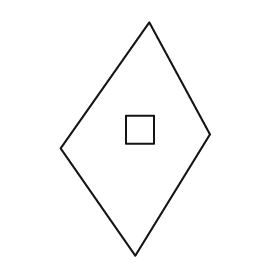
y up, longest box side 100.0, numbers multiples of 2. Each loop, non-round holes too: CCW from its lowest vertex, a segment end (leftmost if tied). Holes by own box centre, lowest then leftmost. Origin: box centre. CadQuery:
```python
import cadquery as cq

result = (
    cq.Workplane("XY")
    .moveTo(0.0, -50.0)
    .lineTo(32.0, 2.0)
    .lineTo(6.0, 50.0)
    .lineTo(-32.0, -4.0)
    .close()
    .moveTo(-4.0, -2.0)
    .lineTo(8.0, -2.0)
    .lineTo(8.0, 10.0)
    .lineTo(-4.0, 10.0)
    .close()
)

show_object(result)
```